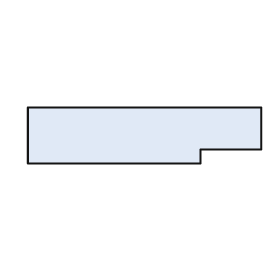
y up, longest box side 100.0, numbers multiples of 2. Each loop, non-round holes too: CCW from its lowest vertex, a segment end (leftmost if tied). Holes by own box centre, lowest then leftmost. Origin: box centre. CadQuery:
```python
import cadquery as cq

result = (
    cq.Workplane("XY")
    .moveTo(-50.0, -12.0)
    .lineTo(24.0, -12.0)
    .lineTo(24.0, -6.0)
    .lineTo(50.0, -6.0)
    .lineTo(50.0, 12.0)
    .lineTo(-50.0, 12.0)
    .close()
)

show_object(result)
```